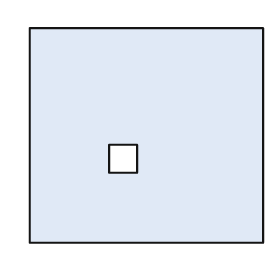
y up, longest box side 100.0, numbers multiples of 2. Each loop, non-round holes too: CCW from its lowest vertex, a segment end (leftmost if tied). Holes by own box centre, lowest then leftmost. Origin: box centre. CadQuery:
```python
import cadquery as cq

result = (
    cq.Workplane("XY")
    .moveTo(-50.0, -46.0)
    .lineTo(50.0, -46.0)
    .lineTo(50.0, 46.0)
    .lineTo(-50.0, 46.0)
    .close()
    .moveTo(-16.0, -16.0)
    .lineTo(-4.0, -16.0)
    .lineTo(-4.0, -4.0)
    .lineTo(-16.0, -4.0)
    .close()
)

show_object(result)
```